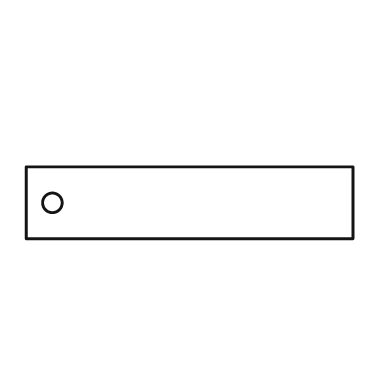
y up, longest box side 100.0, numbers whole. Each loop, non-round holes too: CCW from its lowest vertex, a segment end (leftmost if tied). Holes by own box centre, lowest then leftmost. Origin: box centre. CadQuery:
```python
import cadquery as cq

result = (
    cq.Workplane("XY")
    .moveTo(-50.0, -11.0)
    .lineTo(50.0, -11.0)
    .lineTo(50.0, 11.0)
    .lineTo(-50.0, 11.0)
    .close()
    .moveTo(-42.0, 0.0)
    .circle(3.0)
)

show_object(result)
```